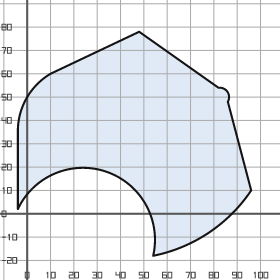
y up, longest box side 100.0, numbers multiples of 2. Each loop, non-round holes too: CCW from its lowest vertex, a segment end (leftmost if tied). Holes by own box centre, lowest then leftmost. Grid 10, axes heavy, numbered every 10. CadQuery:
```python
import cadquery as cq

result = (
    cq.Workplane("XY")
    .moveTo(54.0, -18.0)
    .threePointArc((78.0, -8.0), (96.0, 10.0))
    .lineTo(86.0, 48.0)
    .threePointArc((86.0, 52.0), (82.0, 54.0))
    .lineTo(48.0, 78.0)
    .lineTo(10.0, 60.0)
    .threePointArc((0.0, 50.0), (-4.0, 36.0))
    .lineTo(-4.0, 2.0)
    .threePointArc((34.0, 18.0), (54.0, -18.0))
    .close()
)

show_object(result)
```